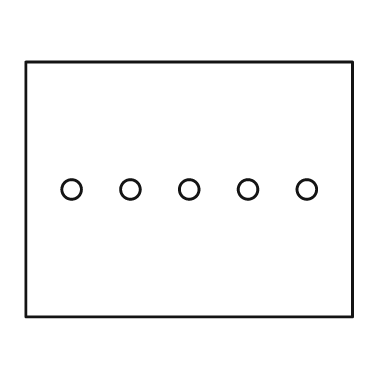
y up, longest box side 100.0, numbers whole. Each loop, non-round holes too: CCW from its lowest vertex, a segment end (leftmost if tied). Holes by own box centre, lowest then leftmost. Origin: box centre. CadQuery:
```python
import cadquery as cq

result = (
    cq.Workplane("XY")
    .moveTo(-50.0, -39.0)
    .lineTo(50.0, -39.0)
    .lineTo(50.0, 39.0)
    .lineTo(-50.0, 39.0)
    .close()
    .moveTo(-36.0, 0.0)
    .circle(3.0)
    .moveTo(-18.0, 0.0)
    .circle(3.0)
    .moveTo(0.0, 0.0)
    .circle(3.0)
    .moveTo(18.0, 0.0)
    .circle(3.0)
    .moveTo(36.0, 0.0)
    .circle(3.0)
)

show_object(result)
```